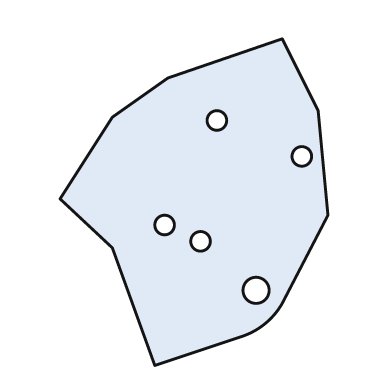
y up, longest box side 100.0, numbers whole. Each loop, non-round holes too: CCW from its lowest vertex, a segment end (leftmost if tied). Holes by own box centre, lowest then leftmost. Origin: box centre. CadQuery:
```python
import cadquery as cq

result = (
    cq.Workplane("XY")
    .moveTo(-12.0, -50.0)
    .lineTo(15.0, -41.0)
    .threePointArc((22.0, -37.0), (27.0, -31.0))
    .lineTo(41.0, -4.0)
    .lineTo(38.0, 28.0)
    .lineTo(27.0, 50.0)
    .lineTo(-8.0, 38.0)
    .lineTo(-25.0, 26.0)
    .lineTo(-41.0, 1.0)
    .lineTo(-25.0, -14.0)
    .close()
    .moveTo(19.0, -27.0)
    .circle(4.0)
    .moveTo(2.0, -12.0)
    .circle(3.0)
    .moveTo(-9.0, -7.0)
    .circle(3.0)
    .moveTo(33.0, 14.0)
    .circle(3.0)
    .moveTo(7.0, 25.0)
    .circle(3.0)
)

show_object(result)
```